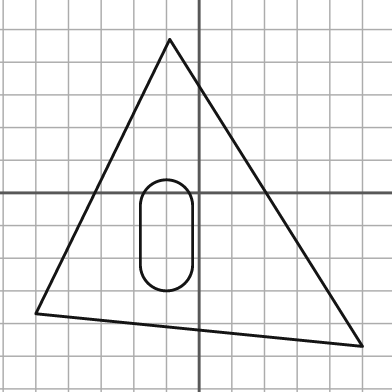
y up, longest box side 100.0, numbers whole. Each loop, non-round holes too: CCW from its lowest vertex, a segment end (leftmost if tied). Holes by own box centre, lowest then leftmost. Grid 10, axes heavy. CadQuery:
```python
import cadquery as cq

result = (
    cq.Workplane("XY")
    .moveTo(50.0, -47.0)
    .lineTo(-9.0, 47.0)
    .lineTo(-50.0, -37.0)
    .close()
    .moveTo(-18.0, -22.0)
    .threePointArc((-10.0, -30.0), (-2.0, -22.0))
    .lineTo(-2.0, -4.0)
    .threePointArc((-10.0, 4.0), (-18.0, -4.0))
    .close()
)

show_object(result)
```